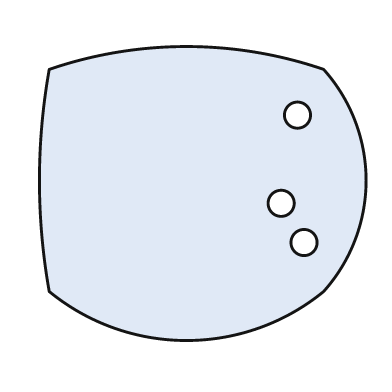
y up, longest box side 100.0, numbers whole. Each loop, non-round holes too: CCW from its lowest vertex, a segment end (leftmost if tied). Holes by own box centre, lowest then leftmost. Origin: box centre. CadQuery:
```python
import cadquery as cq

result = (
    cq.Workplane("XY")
    .moveTo(-47.0, -30.0)
    .threePointArc((-5.0, -45.0), (37.0, -30.0))
    .threePointArc((50.0, 4.0), (37.0, 38.0))
    .threePointArc((-5.0, 45.0), (-47.0, 38.0))
    .threePointArc((-50.0, 4.0), (-47.0, -30.0))
    .close()
    .moveTo(31.0, -15.0)
    .circle(4.0)
    .moveTo(24.0, -3.0)
    .circle(4.0)
    .moveTo(29.0, 24.0)
    .circle(4.0)
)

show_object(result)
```